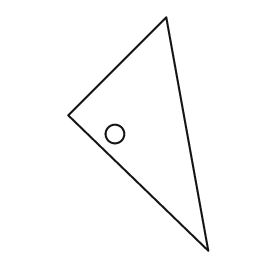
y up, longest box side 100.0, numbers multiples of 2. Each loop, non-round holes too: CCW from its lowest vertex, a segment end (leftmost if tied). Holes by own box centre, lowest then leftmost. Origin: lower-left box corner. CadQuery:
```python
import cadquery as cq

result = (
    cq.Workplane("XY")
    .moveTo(60.0, 0.0)
    .lineTo(42.0, 100.0)
    .lineTo(0.0, 58.0)
    .close()
    .moveTo(20.0, 50.0)
    .circle(4.0)
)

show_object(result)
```